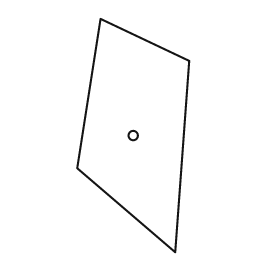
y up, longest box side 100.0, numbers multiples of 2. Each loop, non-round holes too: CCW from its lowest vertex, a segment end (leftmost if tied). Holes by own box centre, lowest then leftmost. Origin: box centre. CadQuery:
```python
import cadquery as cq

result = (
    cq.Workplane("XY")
    .moveTo(18.0, -50.0)
    .lineTo(24.0, 32.0)
    .lineTo(-14.0, 50.0)
    .lineTo(-24.0, -14.0)
    .close()
    .moveTo(0.0, 0.0)
    .circle(2.0)
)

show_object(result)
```